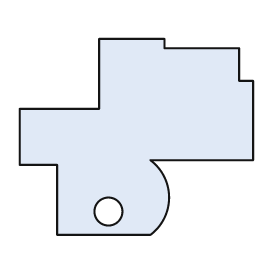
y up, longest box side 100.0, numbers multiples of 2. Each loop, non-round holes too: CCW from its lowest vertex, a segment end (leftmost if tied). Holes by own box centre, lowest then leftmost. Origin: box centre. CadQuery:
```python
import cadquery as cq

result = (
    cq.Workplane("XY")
    .moveTo(-34.0, -42.0)
    .lineTo(6.0, -42.0)
    .threePointArc((14.0, -26.0), (6.0, -10.0))
    .lineTo(50.0, -10.0)
    .lineTo(50.0, 24.0)
    .lineTo(44.0, 24.0)
    .lineTo(44.0, 38.0)
    .lineTo(12.0, 38.0)
    .lineTo(12.0, 42.0)
    .lineTo(-16.0, 42.0)
    .lineTo(-16.0, 12.0)
    .lineTo(-50.0, 12.0)
    .lineTo(-50.0, -12.0)
    .lineTo(-34.0, -12.0)
    .close()
    .moveTo(-12.0, -32.0)
    .circle(6.0)
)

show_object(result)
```